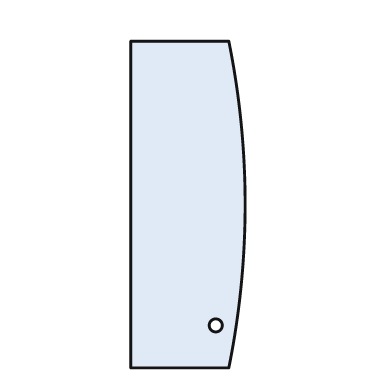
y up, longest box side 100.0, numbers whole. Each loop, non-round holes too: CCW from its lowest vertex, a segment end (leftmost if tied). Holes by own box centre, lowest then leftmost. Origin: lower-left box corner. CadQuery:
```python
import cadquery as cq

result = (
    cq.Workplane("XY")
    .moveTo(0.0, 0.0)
    .lineTo(30.0, 0.0)
    .threePointArc((35.0, 50.0), (30.0, 100.0))
    .lineTo(0.0, 100.0)
    .close()
    .moveTo(26.0, 13.0)
    .circle(2.0)
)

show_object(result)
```